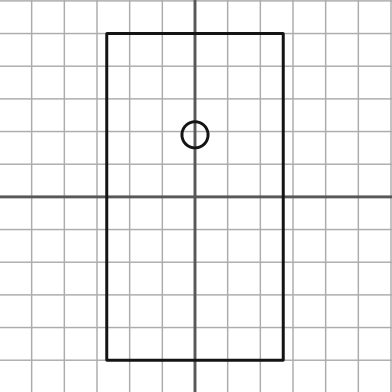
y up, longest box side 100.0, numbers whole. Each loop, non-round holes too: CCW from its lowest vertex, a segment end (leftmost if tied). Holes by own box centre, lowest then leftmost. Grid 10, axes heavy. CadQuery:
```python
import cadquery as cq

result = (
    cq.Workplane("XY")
    .moveTo(-27.0, -50.0)
    .lineTo(27.0, -50.0)
    .lineTo(27.0, 50.0)
    .lineTo(-27.0, 50.0)
    .close()
    .moveTo(0.0, 19.0)
    .circle(4.0)
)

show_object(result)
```